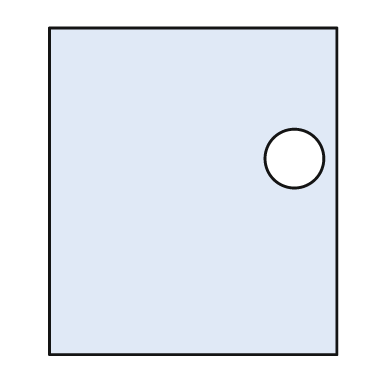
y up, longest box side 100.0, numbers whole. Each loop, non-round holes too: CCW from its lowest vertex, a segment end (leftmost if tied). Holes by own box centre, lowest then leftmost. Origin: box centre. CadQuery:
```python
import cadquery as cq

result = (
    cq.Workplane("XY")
    .moveTo(-44.0, -50.0)
    .lineTo(44.0, -50.0)
    .lineTo(44.0, 50.0)
    .lineTo(-44.0, 50.0)
    .close()
    .moveTo(31.0, 10.0)
    .circle(9.0)
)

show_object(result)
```